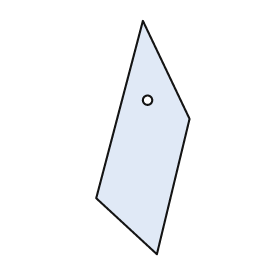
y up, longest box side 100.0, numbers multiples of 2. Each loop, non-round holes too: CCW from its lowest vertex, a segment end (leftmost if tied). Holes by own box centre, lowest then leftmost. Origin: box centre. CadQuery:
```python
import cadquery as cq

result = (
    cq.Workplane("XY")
    .moveTo(6.0, -50.0)
    .lineTo(20.0, 8.0)
    .lineTo(0.0, 50.0)
    .lineTo(-20.0, -26.0)
    .close()
    .moveTo(2.0, 16.0)
    .circle(2.0)
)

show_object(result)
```